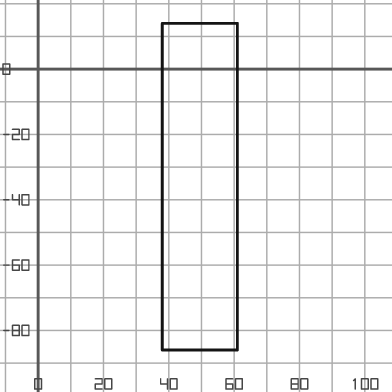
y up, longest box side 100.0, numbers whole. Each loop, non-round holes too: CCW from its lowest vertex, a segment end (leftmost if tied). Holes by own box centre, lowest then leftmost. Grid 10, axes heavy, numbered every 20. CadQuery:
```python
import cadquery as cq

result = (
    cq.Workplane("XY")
    .moveTo(38.0, -86.0)
    .lineTo(61.0, -86.0)
    .lineTo(61.0, 14.0)
    .lineTo(38.0, 14.0)
    .close()
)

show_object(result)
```